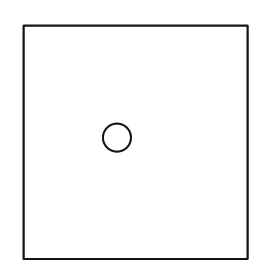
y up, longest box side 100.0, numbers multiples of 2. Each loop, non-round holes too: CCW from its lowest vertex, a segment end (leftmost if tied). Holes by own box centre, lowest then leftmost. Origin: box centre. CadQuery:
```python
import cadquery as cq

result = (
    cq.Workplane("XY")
    .moveTo(-48.0, -50.0)
    .lineTo(48.0, -50.0)
    .lineTo(48.0, 50.0)
    .lineTo(-48.0, 50.0)
    .close()
    .moveTo(-8.0, 2.0)
    .circle(6.0)
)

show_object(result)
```